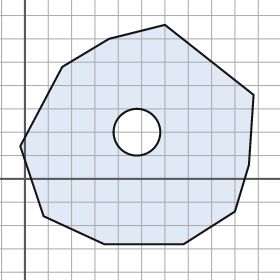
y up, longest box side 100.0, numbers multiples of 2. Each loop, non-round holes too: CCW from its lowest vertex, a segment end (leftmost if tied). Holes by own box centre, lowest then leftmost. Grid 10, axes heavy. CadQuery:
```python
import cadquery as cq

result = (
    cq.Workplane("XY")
    .moveTo(34.0, -28.0)
    .lineTo(68.0, -28.0)
    .lineTo(90.0, -14.0)
    .lineTo(96.0, 6.0)
    .lineTo(98.0, 36.0)
    .lineTo(60.0, 66.0)
    .lineTo(36.0, 60.0)
    .lineTo(16.0, 48.0)
    .lineTo(-2.0, 14.0)
    .lineTo(8.0, -16.0)
    .close()
    .moveTo(48.0, 20.0)
    .circle(10.0)
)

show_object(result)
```